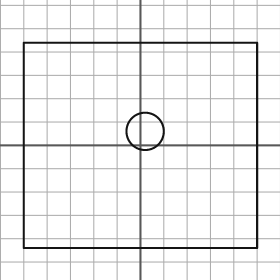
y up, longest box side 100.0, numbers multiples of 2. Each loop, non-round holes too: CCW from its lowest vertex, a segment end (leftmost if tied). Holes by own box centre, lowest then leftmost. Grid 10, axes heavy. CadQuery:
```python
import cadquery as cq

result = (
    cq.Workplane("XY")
    .moveTo(-50.0, -44.0)
    .lineTo(50.0, -44.0)
    .lineTo(50.0, 44.0)
    .lineTo(-50.0, 44.0)
    .close()
    .moveTo(2.0, 6.0)
    .circle(8.0)
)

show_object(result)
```